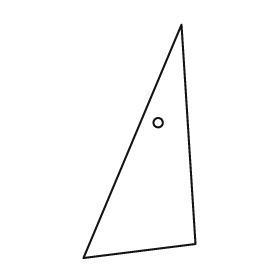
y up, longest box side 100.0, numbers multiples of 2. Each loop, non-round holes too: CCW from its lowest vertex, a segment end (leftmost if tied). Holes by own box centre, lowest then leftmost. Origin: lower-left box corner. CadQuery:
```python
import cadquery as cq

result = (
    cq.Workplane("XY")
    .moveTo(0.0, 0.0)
    .lineTo(48.0, 6.0)
    .lineTo(42.0, 100.0)
    .close()
    .moveTo(32.0, 58.0)
    .circle(2.0)
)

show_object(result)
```